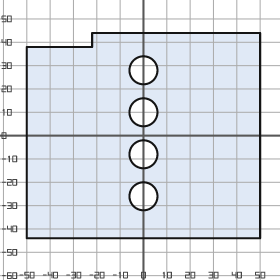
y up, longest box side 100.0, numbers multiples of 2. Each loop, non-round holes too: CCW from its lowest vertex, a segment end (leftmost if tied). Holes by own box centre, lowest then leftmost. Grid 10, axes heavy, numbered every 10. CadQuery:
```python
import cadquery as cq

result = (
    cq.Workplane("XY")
    .moveTo(-50.0, -44.0)
    .lineTo(50.0, -44.0)
    .lineTo(50.0, 44.0)
    .lineTo(-22.0, 44.0)
    .lineTo(-22.0, 38.0)
    .lineTo(-50.0, 38.0)
    .close()
    .moveTo(0.0, -26.0)
    .circle(6.0)
    .moveTo(0.0, -8.0)
    .circle(6.0)
    .moveTo(0.0, 10.0)
    .circle(6.0)
    .moveTo(0.0, 28.0)
    .circle(6.0)
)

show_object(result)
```